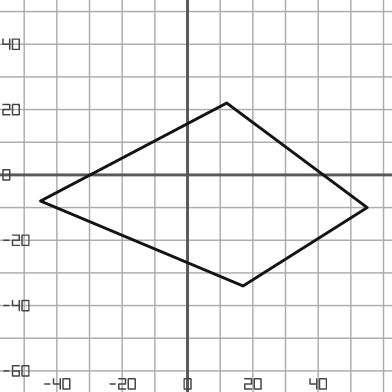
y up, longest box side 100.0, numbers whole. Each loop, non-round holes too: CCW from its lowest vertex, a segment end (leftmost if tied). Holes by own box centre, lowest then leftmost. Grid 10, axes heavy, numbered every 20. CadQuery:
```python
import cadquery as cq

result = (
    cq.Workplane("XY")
    .moveTo(17.0, -34.0)
    .lineTo(55.0, -10.0)
    .lineTo(12.0, 22.0)
    .lineTo(-45.0, -8.0)
    .close()
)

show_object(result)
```